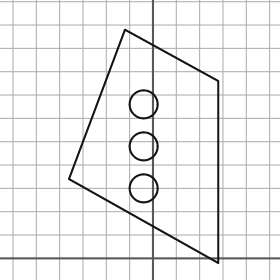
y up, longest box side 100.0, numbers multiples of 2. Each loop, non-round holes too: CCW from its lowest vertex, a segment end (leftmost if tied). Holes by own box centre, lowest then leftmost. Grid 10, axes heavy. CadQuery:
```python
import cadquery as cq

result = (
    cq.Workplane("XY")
    .moveTo(28.0, -2.0)
    .lineTo(28.0, 76.0)
    .lineTo(-12.0, 98.0)
    .lineTo(-36.0, 34.0)
    .close()
    .moveTo(-4.0, 30.0)
    .circle(6.0)
    .moveTo(-4.0, 48.0)
    .circle(6.0)
    .moveTo(-4.0, 66.0)
    .circle(6.0)
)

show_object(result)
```